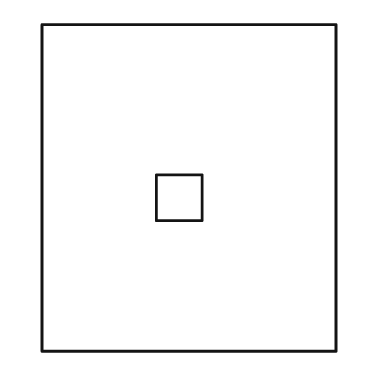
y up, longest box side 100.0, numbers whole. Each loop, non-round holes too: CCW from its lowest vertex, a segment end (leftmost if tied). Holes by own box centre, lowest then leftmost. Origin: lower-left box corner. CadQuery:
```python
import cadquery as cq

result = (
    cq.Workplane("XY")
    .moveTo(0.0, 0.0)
    .lineTo(90.0, 0.0)
    .lineTo(90.0, 100.0)
    .lineTo(0.0, 100.0)
    .close()
    .moveTo(35.0, 40.0)
    .lineTo(49.0, 40.0)
    .lineTo(49.0, 54.0)
    .lineTo(35.0, 54.0)
    .close()
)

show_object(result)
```